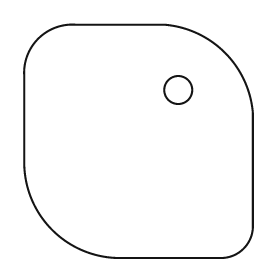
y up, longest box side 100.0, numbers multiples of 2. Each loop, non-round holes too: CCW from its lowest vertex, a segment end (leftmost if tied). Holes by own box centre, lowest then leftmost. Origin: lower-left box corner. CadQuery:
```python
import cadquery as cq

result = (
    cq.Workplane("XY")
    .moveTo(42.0, 0.0)
    .lineTo(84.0, 0.0)
    .threePointArc((94.0, 4.0), (98.0, 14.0))
    .lineTo(98.0, 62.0)
    .threePointArc((86.0, 88.0), (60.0, 100.0))
    .lineTo(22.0, 100.0)
    .threePointArc((6.0, 94.0), (0.0, 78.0))
    .lineTo(0.0, 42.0)
    .threePointArc((12.0, 12.0), (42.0, 0.0))
    .close()
    .moveTo(66.0, 72.0)
    .circle(6.0)
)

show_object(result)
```